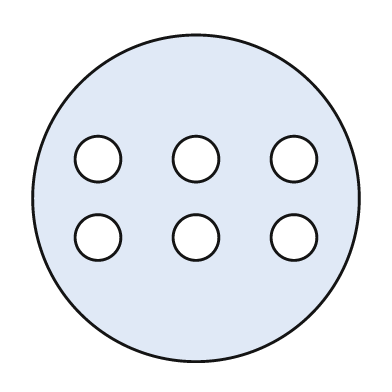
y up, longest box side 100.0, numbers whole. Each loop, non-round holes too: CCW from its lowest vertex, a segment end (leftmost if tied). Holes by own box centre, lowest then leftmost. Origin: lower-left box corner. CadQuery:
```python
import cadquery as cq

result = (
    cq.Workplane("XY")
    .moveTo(50.0, 50.0)
    .circle(50.0)
    .moveTo(20.0, 38.0)
    .circle(7.0)
    .moveTo(50.0, 38.0)
    .circle(7.0)
    .moveTo(80.0, 38.0)
    .circle(7.0)
    .moveTo(20.0, 62.0)
    .circle(7.0)
    .moveTo(50.0, 62.0)
    .circle(7.0)
    .moveTo(80.0, 62.0)
    .circle(7.0)
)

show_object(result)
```